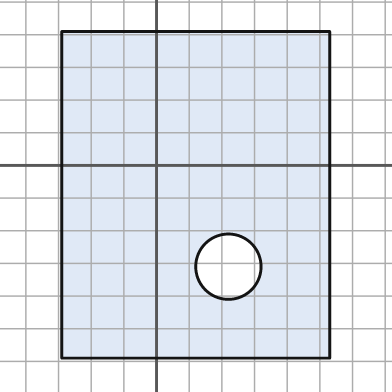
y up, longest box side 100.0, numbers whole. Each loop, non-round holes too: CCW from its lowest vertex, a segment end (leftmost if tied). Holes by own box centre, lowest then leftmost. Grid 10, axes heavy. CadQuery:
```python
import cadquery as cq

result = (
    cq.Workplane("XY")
    .moveTo(-29.0, -59.0)
    .lineTo(53.0, -59.0)
    .lineTo(53.0, 41.0)
    .lineTo(-29.0, 41.0)
    .close()
    .moveTo(22.0, -31.0)
    .circle(10.0)
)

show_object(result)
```